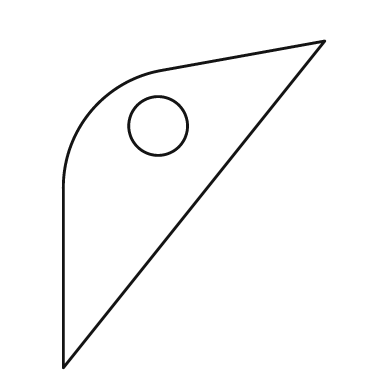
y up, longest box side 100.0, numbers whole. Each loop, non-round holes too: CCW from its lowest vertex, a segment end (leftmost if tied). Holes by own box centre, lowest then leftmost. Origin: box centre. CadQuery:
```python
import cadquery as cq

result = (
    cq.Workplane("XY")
    .moveTo(-40.0, -50.0)
    .lineTo(40.0, 50.0)
    .lineTo(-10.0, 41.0)
    .threePointArc((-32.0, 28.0), (-40.0, 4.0))
    .close()
    .moveTo(-11.0, 24.0)
    .circle(9.0)
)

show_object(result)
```